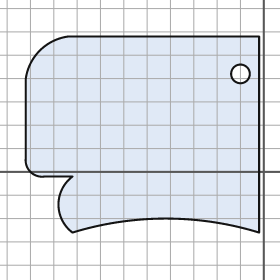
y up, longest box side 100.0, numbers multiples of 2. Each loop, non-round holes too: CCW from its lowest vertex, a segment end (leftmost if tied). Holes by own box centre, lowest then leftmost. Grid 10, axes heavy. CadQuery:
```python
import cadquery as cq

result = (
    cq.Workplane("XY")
    .moveTo(-82.0, -26.0)
    .threePointArc((-42.0, -20.0), (-2.0, -26.0))
    .lineTo(-2.0, 58.0)
    .lineTo(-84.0, 58.0)
    .threePointArc((-96.0, 52.0), (-102.0, 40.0))
    .lineTo(-102.0, 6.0)
    .threePointArc((-100.0, 0.0), (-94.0, -2.0))
    .lineTo(-82.0, -2.0)
    .threePointArc((-88.0, -14.0), (-82.0, -26.0))
    .close()
    .moveTo(-10.0, 42.0)
    .circle(4.0)
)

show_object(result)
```